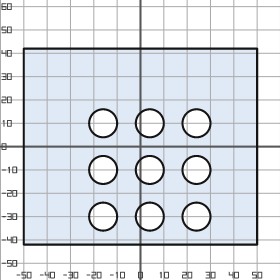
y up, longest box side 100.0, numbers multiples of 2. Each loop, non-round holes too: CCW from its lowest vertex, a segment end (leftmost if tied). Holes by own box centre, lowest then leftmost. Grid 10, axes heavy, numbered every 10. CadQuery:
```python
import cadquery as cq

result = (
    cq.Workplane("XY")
    .moveTo(-50.0, -42.0)
    .lineTo(50.0, -42.0)
    .lineTo(50.0, 42.0)
    .lineTo(-50.0, 42.0)
    .close()
    .moveTo(-16.0, -30.0)
    .circle(6.0)
    .moveTo(4.0, -30.0)
    .circle(6.0)
    .moveTo(24.0, -30.0)
    .circle(6.0)
    .moveTo(-16.0, -10.0)
    .circle(6.0)
    .moveTo(4.0, -10.0)
    .circle(6.0)
    .moveTo(24.0, -10.0)
    .circle(6.0)
    .moveTo(-16.0, 10.0)
    .circle(6.0)
    .moveTo(4.0, 10.0)
    .circle(6.0)
    .moveTo(24.0, 10.0)
    .circle(6.0)
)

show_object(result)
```